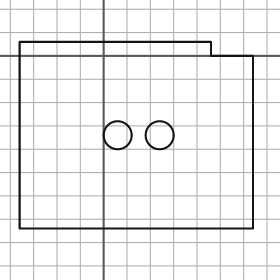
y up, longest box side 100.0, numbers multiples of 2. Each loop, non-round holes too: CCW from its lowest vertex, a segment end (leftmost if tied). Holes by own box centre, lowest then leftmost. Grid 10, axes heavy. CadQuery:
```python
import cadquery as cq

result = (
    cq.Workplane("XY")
    .moveTo(-36.0, -74.0)
    .lineTo(64.0, -74.0)
    .lineTo(64.0, 0.0)
    .lineTo(46.0, 0.0)
    .lineTo(46.0, 6.0)
    .lineTo(-36.0, 6.0)
    .close()
    .moveTo(6.0, -34.0)
    .circle(6.0)
    .moveTo(24.0, -34.0)
    .circle(6.0)
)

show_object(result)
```